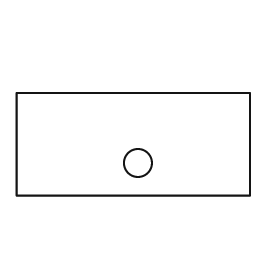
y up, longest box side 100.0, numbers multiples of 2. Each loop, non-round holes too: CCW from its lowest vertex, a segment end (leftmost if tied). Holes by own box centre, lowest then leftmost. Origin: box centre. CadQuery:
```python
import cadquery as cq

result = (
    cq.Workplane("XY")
    .moveTo(-50.0, -22.0)
    .lineTo(50.0, -22.0)
    .lineTo(50.0, 22.0)
    .lineTo(-50.0, 22.0)
    .close()
    .moveTo(2.0, -8.0)
    .circle(6.0)
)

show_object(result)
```